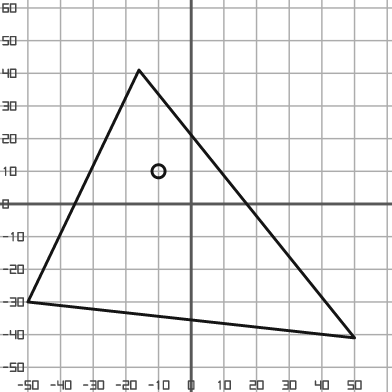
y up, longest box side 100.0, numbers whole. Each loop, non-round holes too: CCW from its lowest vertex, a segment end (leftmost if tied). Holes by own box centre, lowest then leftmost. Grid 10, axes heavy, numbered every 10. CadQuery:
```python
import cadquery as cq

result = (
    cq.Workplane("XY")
    .moveTo(50.0, -41.0)
    .lineTo(-16.0, 41.0)
    .lineTo(-50.0, -30.0)
    .close()
    .moveTo(-10.0, 10.0)
    .circle(2.0)
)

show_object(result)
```